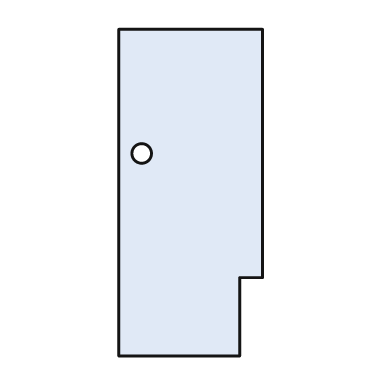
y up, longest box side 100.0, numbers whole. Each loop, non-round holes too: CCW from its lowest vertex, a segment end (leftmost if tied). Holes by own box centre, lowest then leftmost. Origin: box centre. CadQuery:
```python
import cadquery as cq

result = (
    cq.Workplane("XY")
    .moveTo(-22.0, -50.0)
    .lineTo(15.0, -50.0)
    .lineTo(15.0, -26.0)
    .lineTo(22.0, -26.0)
    .lineTo(22.0, 50.0)
    .lineTo(-22.0, 50.0)
    .close()
    .moveTo(-15.0, 12.0)
    .circle(3.0)
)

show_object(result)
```